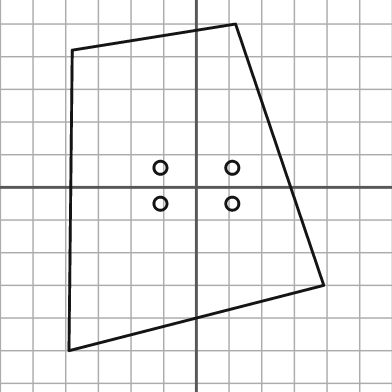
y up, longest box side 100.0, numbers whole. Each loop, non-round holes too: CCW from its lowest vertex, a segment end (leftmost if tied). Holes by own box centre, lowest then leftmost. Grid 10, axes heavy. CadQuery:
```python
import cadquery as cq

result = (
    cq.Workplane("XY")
    .moveTo(-39.0, -50.0)
    .lineTo(39.0, -30.0)
    .lineTo(12.0, 50.0)
    .lineTo(-38.0, 42.0)
    .close()
    .moveTo(-11.0, -5.0)
    .circle(2.0)
    .moveTo(11.0, -5.0)
    .circle(2.0)
    .moveTo(-11.0, 6.0)
    .circle(2.0)
    .moveTo(11.0, 6.0)
    .circle(2.0)
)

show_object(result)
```